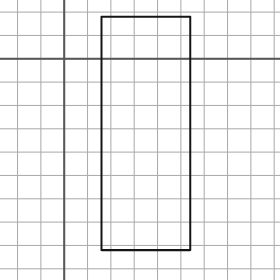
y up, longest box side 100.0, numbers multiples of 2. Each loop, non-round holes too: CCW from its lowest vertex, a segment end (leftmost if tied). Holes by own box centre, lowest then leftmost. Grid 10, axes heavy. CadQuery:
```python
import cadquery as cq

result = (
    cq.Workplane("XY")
    .moveTo(16.0, -82.0)
    .lineTo(54.0, -82.0)
    .lineTo(54.0, 18.0)
    .lineTo(16.0, 18.0)
    .close()
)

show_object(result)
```